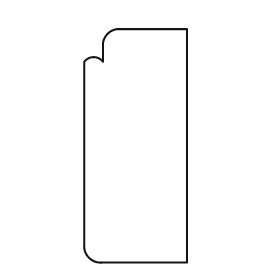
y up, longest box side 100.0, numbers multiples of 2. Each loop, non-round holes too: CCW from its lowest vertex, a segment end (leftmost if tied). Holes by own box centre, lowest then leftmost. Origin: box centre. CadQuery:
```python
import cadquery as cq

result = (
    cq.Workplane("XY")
    .moveTo(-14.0, -50.0)
    .lineTo(22.0, -50.0)
    .lineTo(22.0, 50.0)
    .lineTo(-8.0, 50.0)
    .threePointArc((-12.0, 48.0), (-14.0, 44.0))
    .lineTo(-14.0, 36.0)
    .threePointArc((-18.0, 38.0), (-22.0, 36.0))
    .lineTo(-22.0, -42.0)
    .threePointArc((-20.0, -48.0), (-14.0, -50.0))
    .close()
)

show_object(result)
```